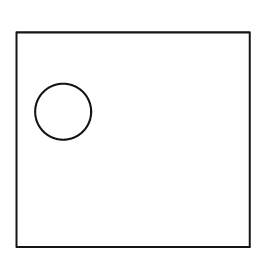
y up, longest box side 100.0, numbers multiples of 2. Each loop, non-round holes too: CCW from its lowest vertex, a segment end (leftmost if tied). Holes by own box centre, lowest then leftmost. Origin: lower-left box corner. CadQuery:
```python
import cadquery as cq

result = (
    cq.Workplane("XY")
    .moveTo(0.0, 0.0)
    .lineTo(100.0, 0.0)
    .lineTo(100.0, 92.0)
    .lineTo(0.0, 92.0)
    .close()
    .moveTo(20.0, 58.0)
    .circle(12.0)
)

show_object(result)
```